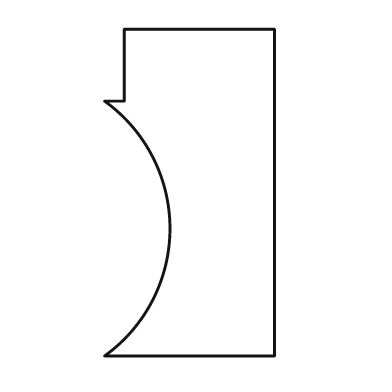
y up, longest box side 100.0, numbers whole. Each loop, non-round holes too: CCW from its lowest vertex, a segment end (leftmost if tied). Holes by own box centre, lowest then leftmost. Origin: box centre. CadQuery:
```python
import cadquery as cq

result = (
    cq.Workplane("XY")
    .moveTo(-26.0, -50.0)
    .lineTo(26.0, -50.0)
    .lineTo(26.0, 50.0)
    .lineTo(-20.0, 50.0)
    .lineTo(-20.0, 28.0)
    .lineTo(-26.0, 28.0)
    .threePointArc((-6.0, -11.0), (-26.0, -50.0))
    .close()
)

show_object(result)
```